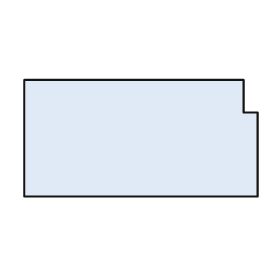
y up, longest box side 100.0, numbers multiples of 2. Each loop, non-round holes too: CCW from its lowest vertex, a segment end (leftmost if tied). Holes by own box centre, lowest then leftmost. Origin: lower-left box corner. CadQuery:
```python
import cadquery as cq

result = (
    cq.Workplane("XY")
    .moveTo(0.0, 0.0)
    .lineTo(100.0, 0.0)
    .lineTo(100.0, 36.0)
    .lineTo(94.0, 36.0)
    .lineTo(94.0, 50.0)
    .lineTo(0.0, 50.0)
    .close()
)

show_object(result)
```